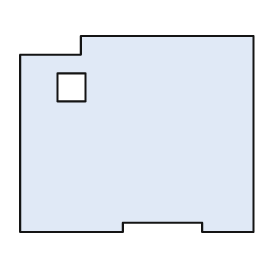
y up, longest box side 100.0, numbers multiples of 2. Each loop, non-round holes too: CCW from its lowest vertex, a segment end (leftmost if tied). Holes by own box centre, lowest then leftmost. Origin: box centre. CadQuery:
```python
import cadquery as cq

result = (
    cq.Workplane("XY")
    .moveTo(-50.0, -42.0)
    .lineTo(-6.0, -42.0)
    .lineTo(-6.0, -38.0)
    .lineTo(28.0, -38.0)
    .lineTo(28.0, -42.0)
    .lineTo(50.0, -42.0)
    .lineTo(50.0, 42.0)
    .lineTo(-24.0, 42.0)
    .lineTo(-24.0, 34.0)
    .lineTo(-50.0, 34.0)
    .close()
    .moveTo(-34.0, 14.0)
    .lineTo(-22.0, 14.0)
    .lineTo(-22.0, 26.0)
    .lineTo(-34.0, 26.0)
    .close()
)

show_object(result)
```